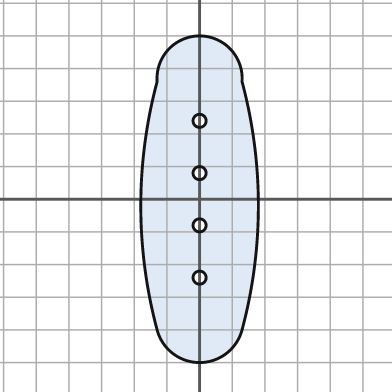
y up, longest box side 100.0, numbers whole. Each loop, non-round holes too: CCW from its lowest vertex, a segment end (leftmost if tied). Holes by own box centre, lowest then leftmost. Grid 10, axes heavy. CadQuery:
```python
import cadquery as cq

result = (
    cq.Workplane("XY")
    .moveTo(-13.0, -40.0)
    .threePointArc((0.0, -50.0), (13.0, -40.0))
    .threePointArc((18.0, -2.0), (13.0, 36.0))
    .threePointArc((0.0, 50.0), (-13.0, 36.0))
    .threePointArc((-18.0, -2.0), (-13.0, -40.0))
    .close()
    .moveTo(0.0, -24.0)
    .circle(2.0)
    .moveTo(0.0, -8.0)
    .circle(2.0)
    .moveTo(0.0, 8.0)
    .circle(2.0)
    .moveTo(0.0, 24.0)
    .circle(2.0)
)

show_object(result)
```